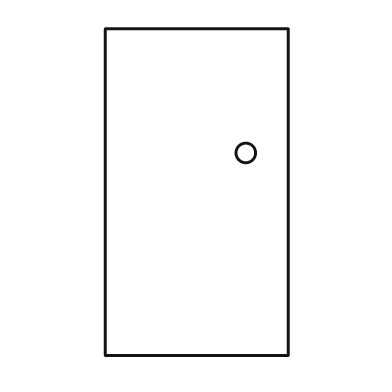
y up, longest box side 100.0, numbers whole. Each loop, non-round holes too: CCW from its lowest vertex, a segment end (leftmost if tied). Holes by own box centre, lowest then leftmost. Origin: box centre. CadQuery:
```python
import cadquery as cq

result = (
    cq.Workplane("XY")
    .moveTo(-28.0, -50.0)
    .lineTo(28.0, -50.0)
    .lineTo(28.0, 50.0)
    .lineTo(-28.0, 50.0)
    .close()
    .moveTo(15.0, 12.0)
    .circle(3.0)
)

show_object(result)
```